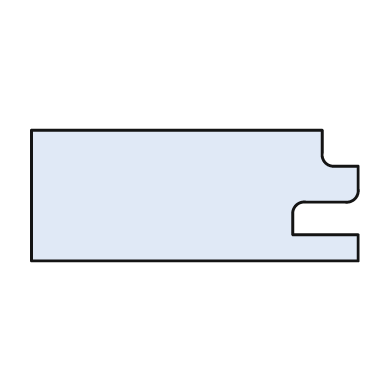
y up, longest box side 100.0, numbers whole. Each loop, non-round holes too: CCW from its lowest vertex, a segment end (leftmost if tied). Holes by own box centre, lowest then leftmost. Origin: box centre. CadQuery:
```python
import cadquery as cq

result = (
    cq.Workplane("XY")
    .moveTo(-50.0, -20.0)
    .lineTo(50.0, -20.0)
    .lineTo(50.0, -12.0)
    .lineTo(30.0, -12.0)
    .lineTo(30.0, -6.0)
    .threePointArc((31.0, -3.0), (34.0, -2.0))
    .lineTo(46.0, -2.0)
    .threePointArc((49.0, -1.0), (50.0, 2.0))
    .lineTo(50.0, 9.0)
    .lineTo(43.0, 9.0)
    .threePointArc((40.0, 10.0), (39.0, 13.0))
    .lineTo(39.0, 20.0)
    .lineTo(-50.0, 20.0)
    .close()
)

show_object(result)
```